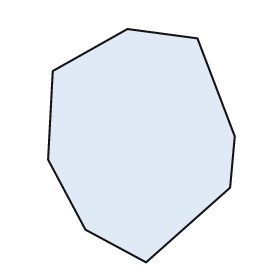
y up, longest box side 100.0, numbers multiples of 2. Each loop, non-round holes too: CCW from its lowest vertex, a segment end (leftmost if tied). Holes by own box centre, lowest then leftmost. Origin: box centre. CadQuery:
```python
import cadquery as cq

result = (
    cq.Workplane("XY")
    .moveTo(2.0, -50.0)
    .lineTo(38.0, -18.0)
    .lineTo(40.0, 4.0)
    .lineTo(24.0, 46.0)
    .lineTo(-6.0, 50.0)
    .lineTo(-38.0, 32.0)
    .lineTo(-40.0, -6.0)
    .lineTo(-24.0, -36.0)
    .close()
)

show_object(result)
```